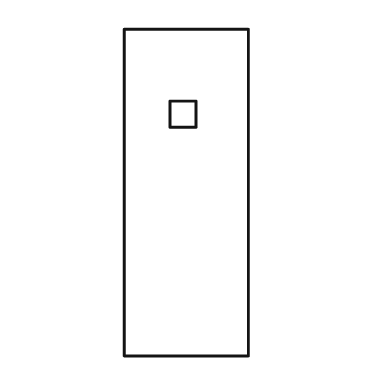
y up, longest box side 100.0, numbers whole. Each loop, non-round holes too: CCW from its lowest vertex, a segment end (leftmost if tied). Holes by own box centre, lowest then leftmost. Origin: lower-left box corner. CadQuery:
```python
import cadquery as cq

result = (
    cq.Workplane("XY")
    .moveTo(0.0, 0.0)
    .lineTo(38.0, 0.0)
    .lineTo(38.0, 100.0)
    .lineTo(0.0, 100.0)
    .close()
    .moveTo(14.0, 70.0)
    .lineTo(22.0, 70.0)
    .lineTo(22.0, 78.0)
    .lineTo(14.0, 78.0)
    .close()
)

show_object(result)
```